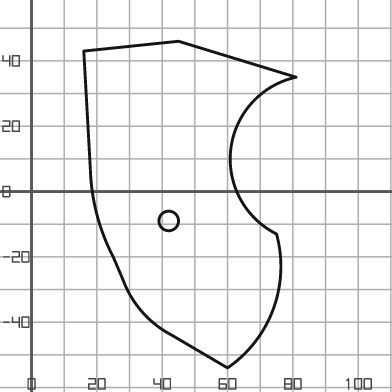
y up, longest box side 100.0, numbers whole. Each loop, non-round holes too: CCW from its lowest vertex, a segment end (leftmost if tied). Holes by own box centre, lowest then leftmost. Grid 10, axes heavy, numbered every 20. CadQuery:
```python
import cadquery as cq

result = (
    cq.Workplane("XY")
    .moveTo(60.0, -54.0)
    .threePointArc((74.0, -36.0), (75.0, -13.0))
    .threePointArc((61.0, 13.0), (81.0, 35.0))
    .lineTo(45.0, 46.0)
    .lineTo(16.0, 43.0)
    .lineTo(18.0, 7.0)
    .threePointArc((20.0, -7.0), (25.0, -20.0))
    .lineTo(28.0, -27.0)
    .threePointArc((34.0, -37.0), (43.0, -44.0))
    .close()
    .moveTo(42.0, -9.0)
    .circle(3.0)
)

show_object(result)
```